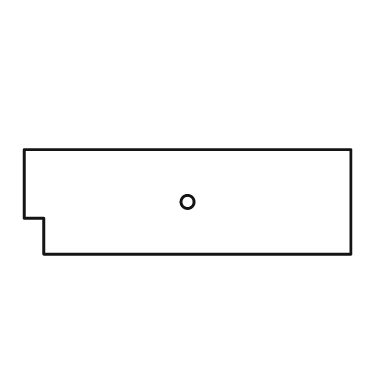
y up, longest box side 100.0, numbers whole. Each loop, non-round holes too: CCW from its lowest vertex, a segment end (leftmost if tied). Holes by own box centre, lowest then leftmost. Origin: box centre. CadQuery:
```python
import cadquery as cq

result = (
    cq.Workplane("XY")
    .moveTo(-44.0, -16.0)
    .lineTo(50.0, -16.0)
    .lineTo(50.0, 16.0)
    .lineTo(-50.0, 16.0)
    .lineTo(-50.0, -5.0)
    .lineTo(-44.0, -5.0)
    .close()
    .moveTo(0.0, 0.0)
    .circle(2.0)
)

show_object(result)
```